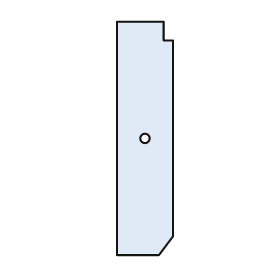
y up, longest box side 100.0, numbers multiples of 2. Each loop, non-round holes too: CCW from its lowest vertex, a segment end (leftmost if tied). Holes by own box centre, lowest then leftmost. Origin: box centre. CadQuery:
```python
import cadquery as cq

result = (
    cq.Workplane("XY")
    .moveTo(-12.0, -50.0)
    .lineTo(6.0, -50.0)
    .lineTo(12.0, -42.0)
    .lineTo(12.0, 42.0)
    .lineTo(8.0, 42.0)
    .lineTo(8.0, 50.0)
    .lineTo(-12.0, 50.0)
    .close()
    .moveTo(0.0, 0.0)
    .circle(2.0)
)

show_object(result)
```